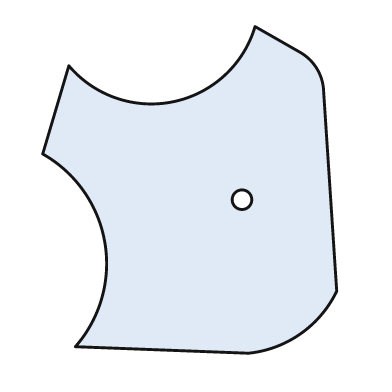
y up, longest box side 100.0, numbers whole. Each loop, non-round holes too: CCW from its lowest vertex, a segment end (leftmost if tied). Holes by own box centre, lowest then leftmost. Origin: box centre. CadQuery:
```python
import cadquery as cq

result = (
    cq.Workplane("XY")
    .moveTo(18.0, -50.0)
    .threePointArc((34.0, -44.0), (45.0, -31.0))
    .lineTo(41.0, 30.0)
    .threePointArc((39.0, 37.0), (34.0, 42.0))
    .lineTo(20.0, 50.0)
    .threePointArc((-5.0, 27.0), (-37.0, 38.0))
    .lineTo(-45.0, 11.0)
    .threePointArc((-26.0, -16.0), (-35.0, -48.0))
    .close()
    .moveTo(16.0, -3.0)
    .circle(3.0)
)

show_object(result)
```